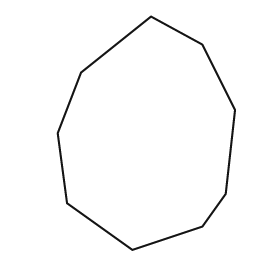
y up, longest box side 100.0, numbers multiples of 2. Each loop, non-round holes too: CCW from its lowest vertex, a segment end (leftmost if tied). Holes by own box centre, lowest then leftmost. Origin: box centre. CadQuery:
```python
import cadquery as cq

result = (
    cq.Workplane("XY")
    .moveTo(-6.0, -50.0)
    .lineTo(24.0, -40.0)
    .lineTo(34.0, -26.0)
    .lineTo(38.0, 10.0)
    .lineTo(24.0, 38.0)
    .lineTo(2.0, 50.0)
    .lineTo(-28.0, 26.0)
    .lineTo(-38.0, 0.0)
    .lineTo(-34.0, -30.0)
    .close()
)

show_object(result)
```